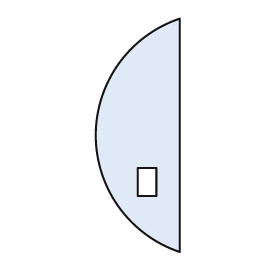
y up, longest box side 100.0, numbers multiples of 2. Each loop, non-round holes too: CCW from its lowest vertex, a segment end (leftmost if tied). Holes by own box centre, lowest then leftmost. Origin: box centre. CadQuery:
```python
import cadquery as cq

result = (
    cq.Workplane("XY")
    .moveTo(18.0, -50.0)
    .lineTo(18.0, 50.0)
    .threePointArc((-18.0, 0.0), (18.0, -50.0))
    .close()
    .moveTo(0.0, -26.0)
    .lineTo(8.0, -26.0)
    .lineTo(8.0, -14.0)
    .lineTo(0.0, -14.0)
    .close()
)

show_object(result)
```